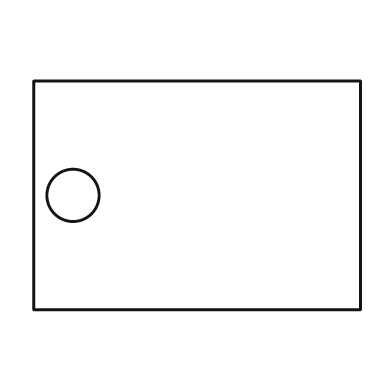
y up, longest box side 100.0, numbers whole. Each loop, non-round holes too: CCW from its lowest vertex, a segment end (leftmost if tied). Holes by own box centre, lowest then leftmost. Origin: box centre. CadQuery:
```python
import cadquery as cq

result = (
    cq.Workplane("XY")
    .moveTo(-50.0, -35.0)
    .lineTo(50.0, -35.0)
    .lineTo(50.0, 35.0)
    .lineTo(-50.0, 35.0)
    .close()
    .moveTo(-38.0, 0.0)
    .circle(8.0)
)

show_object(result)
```